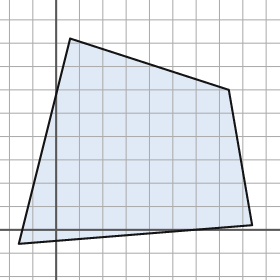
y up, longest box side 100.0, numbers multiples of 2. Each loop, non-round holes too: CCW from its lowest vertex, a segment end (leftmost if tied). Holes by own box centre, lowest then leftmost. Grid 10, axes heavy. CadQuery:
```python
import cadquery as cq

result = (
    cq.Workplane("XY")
    .moveTo(-16.0, -6.0)
    .lineTo(84.0, 2.0)
    .lineTo(74.0, 60.0)
    .lineTo(6.0, 82.0)
    .close()
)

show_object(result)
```